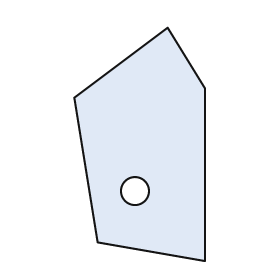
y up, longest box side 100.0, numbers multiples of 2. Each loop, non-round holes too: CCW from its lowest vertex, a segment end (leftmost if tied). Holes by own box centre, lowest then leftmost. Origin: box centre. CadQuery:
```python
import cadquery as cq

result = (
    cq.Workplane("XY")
    .moveTo(28.0, -50.0)
    .lineTo(28.0, 24.0)
    .lineTo(12.0, 50.0)
    .lineTo(-28.0, 20.0)
    .lineTo(-18.0, -42.0)
    .close()
    .moveTo(-2.0, -20.0)
    .circle(6.0)
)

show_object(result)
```